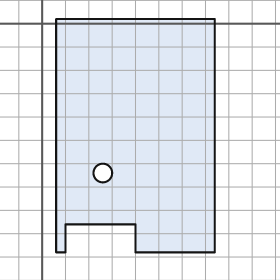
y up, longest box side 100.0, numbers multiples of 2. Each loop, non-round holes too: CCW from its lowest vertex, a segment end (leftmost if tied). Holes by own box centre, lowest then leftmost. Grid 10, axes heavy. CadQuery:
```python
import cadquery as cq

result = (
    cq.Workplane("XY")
    .moveTo(6.0, -98.0)
    .lineTo(10.0, -98.0)
    .lineTo(10.0, -86.0)
    .lineTo(40.0, -86.0)
    .lineTo(40.0, -98.0)
    .lineTo(74.0, -98.0)
    .lineTo(74.0, 2.0)
    .lineTo(6.0, 2.0)
    .close()
    .moveTo(26.0, -64.0)
    .circle(4.0)
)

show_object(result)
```